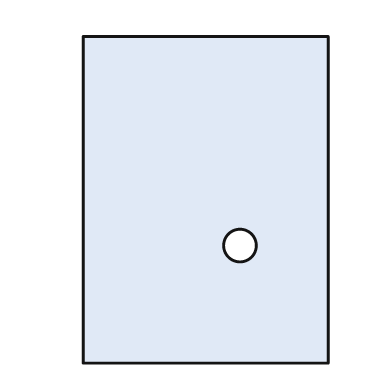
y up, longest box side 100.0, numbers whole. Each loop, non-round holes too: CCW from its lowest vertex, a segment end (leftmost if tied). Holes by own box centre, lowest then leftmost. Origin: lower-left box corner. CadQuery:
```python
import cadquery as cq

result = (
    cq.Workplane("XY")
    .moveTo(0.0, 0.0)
    .lineTo(75.0, 0.0)
    .lineTo(75.0, 100.0)
    .lineTo(0.0, 100.0)
    .close()
    .moveTo(48.0, 36.0)
    .circle(5.0)
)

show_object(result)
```